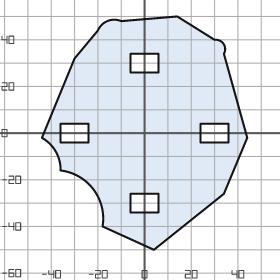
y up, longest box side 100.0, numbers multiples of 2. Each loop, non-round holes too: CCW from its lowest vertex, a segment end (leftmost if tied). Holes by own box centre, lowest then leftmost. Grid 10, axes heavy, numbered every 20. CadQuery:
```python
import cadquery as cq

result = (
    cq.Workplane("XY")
    .moveTo(4.0, -50.0)
    .lineTo(34.0, -26.0)
    .lineTo(44.0, -2.0)
    .lineTo(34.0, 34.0)
    .threePointArc((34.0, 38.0), (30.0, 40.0))
    .lineTo(14.0, 50.0)
    .lineTo(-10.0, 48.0)
    .threePointArc((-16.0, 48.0), (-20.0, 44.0))
    .lineTo(-30.0, 32.0)
    .lineTo(-44.0, -2.0)
    .threePointArc((-38.0, -8.0), (-36.0, -16.0))
    .threePointArc((-22.0, -24.0), (-18.0, -40.0))
    .close()
    .moveTo(-6.0, -34.0)
    .lineTo(6.0, -34.0)
    .lineTo(6.0, -26.0)
    .lineTo(-6.0, -26.0)
    .close()
    .moveTo(-36.0, -4.0)
    .lineTo(-24.0, -4.0)
    .lineTo(-24.0, 4.0)
    .lineTo(-36.0, 4.0)
    .close()
    .moveTo(24.0, -4.0)
    .lineTo(36.0, -4.0)
    .lineTo(36.0, 4.0)
    .lineTo(24.0, 4.0)
    .close()
    .moveTo(-6.0, 26.0)
    .lineTo(6.0, 26.0)
    .lineTo(6.0, 34.0)
    .lineTo(-6.0, 34.0)
    .close()
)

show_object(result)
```